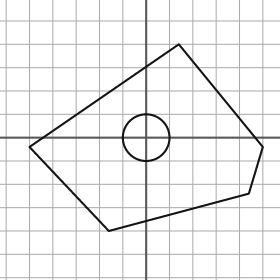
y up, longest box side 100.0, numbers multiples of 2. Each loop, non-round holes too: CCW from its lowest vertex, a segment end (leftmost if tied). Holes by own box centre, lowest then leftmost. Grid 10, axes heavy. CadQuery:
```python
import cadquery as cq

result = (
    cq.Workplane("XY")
    .moveTo(-16.0, -40.0)
    .lineTo(44.0, -24.0)
    .lineTo(50.0, -4.0)
    .lineTo(14.0, 40.0)
    .lineTo(-50.0, -4.0)
    .close()
    .moveTo(0.0, 0.0)
    .circle(10.0)
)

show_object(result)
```